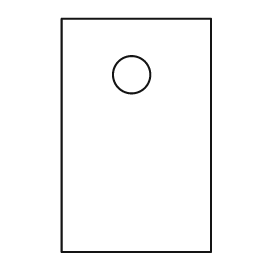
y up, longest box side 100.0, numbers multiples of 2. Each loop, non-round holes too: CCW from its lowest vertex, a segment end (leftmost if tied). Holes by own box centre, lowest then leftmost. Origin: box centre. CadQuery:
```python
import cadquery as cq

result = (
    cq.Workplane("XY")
    .moveTo(-32.0, -50.0)
    .lineTo(32.0, -50.0)
    .lineTo(32.0, 50.0)
    .lineTo(-32.0, 50.0)
    .close()
    .moveTo(-2.0, 26.0)
    .circle(8.0)
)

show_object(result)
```